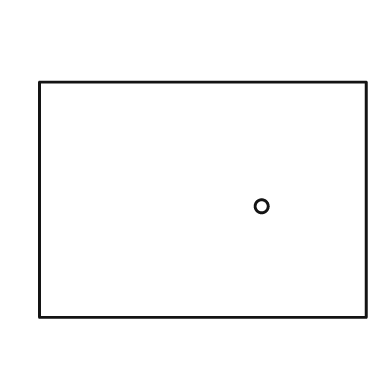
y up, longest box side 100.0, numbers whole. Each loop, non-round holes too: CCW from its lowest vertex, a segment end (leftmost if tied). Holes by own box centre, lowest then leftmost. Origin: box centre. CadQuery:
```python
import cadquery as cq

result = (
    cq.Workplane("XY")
    .moveTo(-50.0, -36.0)
    .lineTo(50.0, -36.0)
    .lineTo(50.0, 36.0)
    .lineTo(-50.0, 36.0)
    .close()
    .moveTo(18.0, -2.0)
    .circle(2.0)
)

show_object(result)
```